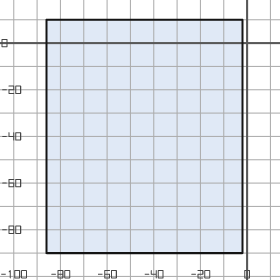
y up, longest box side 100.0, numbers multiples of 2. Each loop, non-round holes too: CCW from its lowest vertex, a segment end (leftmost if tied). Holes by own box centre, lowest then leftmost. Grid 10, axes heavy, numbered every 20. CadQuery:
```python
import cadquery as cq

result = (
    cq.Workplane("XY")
    .moveTo(-86.0, -90.0)
    .lineTo(-2.0, -90.0)
    .lineTo(-2.0, 10.0)
    .lineTo(-86.0, 10.0)
    .close()
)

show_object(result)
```